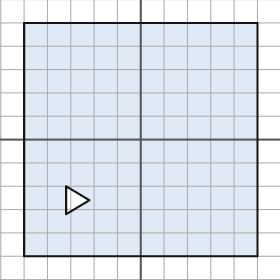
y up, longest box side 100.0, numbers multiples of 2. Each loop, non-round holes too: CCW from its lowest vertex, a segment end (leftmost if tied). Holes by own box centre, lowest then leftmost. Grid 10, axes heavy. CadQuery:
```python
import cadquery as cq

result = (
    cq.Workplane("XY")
    .moveTo(-50.0, -50.0)
    .lineTo(50.0, -50.0)
    .lineTo(50.0, 50.0)
    .lineTo(-50.0, 50.0)
    .close()
    .moveTo(-32.0, -32.0)
    .lineTo(-22.0, -26.0)
    .lineTo(-32.0, -20.0)
    .close()
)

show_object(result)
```